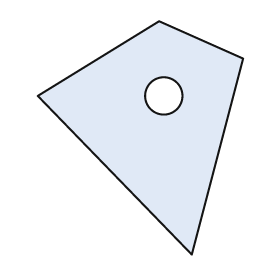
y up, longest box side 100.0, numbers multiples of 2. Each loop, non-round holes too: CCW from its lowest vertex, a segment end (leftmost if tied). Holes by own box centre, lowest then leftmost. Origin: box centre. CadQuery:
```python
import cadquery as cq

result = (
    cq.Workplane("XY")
    .moveTo(22.0, -50.0)
    .lineTo(44.0, 34.0)
    .lineTo(8.0, 50.0)
    .lineTo(-44.0, 18.0)
    .close()
    .moveTo(10.0, 18.0)
    .circle(8.0)
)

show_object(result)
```